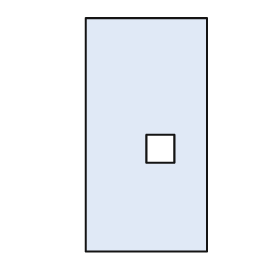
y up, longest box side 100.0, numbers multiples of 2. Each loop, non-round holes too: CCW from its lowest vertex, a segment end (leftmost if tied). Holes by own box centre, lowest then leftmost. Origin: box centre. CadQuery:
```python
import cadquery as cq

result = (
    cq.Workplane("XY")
    .moveTo(-26.0, -50.0)
    .lineTo(26.0, -50.0)
    .lineTo(26.0, 50.0)
    .lineTo(-26.0, 50.0)
    .close()
    .moveTo(0.0, -12.0)
    .lineTo(12.0, -12.0)
    .lineTo(12.0, 0.0)
    .lineTo(0.0, 0.0)
    .close()
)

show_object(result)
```